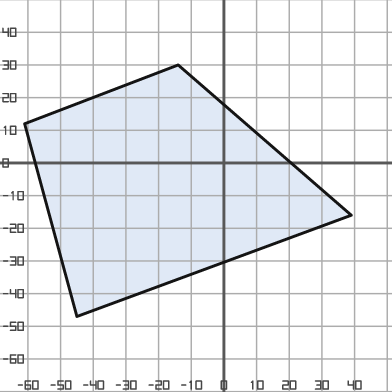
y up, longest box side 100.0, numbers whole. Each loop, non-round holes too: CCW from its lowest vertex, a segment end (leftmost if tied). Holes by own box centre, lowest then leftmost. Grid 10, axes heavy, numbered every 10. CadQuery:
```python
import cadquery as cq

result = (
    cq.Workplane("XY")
    .moveTo(-45.0, -47.0)
    .lineTo(39.0, -16.0)
    .lineTo(-14.0, 30.0)
    .lineTo(-61.0, 12.0)
    .close()
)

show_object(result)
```